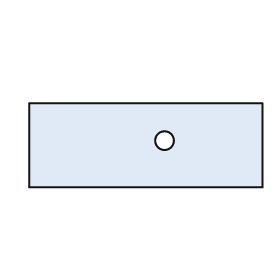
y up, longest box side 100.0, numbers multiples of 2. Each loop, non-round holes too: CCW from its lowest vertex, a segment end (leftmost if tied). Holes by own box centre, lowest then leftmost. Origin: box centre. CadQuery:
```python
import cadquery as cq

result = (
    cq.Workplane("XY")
    .moveTo(-50.0, -18.0)
    .lineTo(50.0, -18.0)
    .lineTo(50.0, 18.0)
    .lineTo(-50.0, 18.0)
    .close()
    .moveTo(8.0, 2.0)
    .circle(4.0)
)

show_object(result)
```